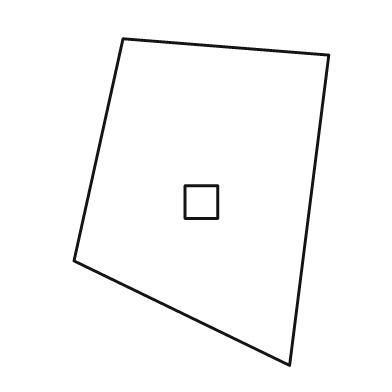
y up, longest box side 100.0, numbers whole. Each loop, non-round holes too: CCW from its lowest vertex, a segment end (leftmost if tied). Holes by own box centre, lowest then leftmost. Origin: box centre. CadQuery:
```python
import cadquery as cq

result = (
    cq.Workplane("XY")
    .moveTo(27.0, -50.0)
    .lineTo(39.0, 45.0)
    .lineTo(-24.0, 50.0)
    .lineTo(-39.0, -18.0)
    .close()
    .moveTo(-5.0, -5.0)
    .lineTo(5.0, -5.0)
    .lineTo(5.0, 5.0)
    .lineTo(-5.0, 5.0)
    .close()
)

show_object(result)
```